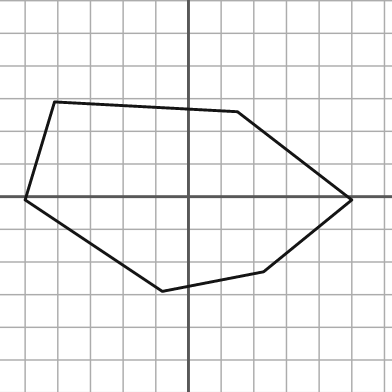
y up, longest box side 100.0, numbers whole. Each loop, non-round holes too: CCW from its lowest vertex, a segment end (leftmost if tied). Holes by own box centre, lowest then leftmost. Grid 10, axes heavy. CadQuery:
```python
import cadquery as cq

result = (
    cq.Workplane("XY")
    .moveTo(-8.0, -29.0)
    .lineTo(23.0, -23.0)
    .lineTo(50.0, -1.0)
    .lineTo(15.0, 26.0)
    .lineTo(-41.0, 29.0)
    .lineTo(-50.0, -1.0)
    .close()
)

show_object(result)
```